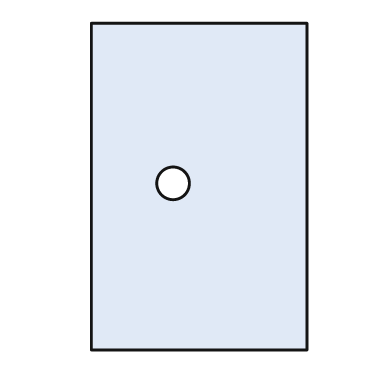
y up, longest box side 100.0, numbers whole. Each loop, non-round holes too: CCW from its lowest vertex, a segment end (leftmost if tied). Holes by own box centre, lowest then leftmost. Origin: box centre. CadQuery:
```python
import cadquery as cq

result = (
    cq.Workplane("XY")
    .moveTo(-33.0, -50.0)
    .lineTo(33.0, -50.0)
    .lineTo(33.0, 50.0)
    .lineTo(-33.0, 50.0)
    .close()
    .moveTo(-8.0, 1.0)
    .circle(5.0)
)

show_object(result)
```